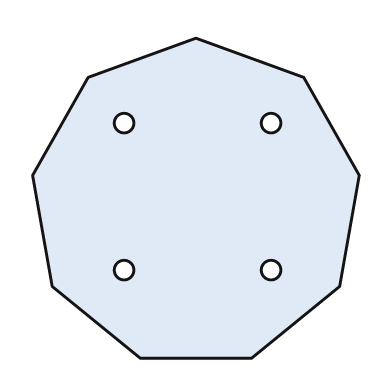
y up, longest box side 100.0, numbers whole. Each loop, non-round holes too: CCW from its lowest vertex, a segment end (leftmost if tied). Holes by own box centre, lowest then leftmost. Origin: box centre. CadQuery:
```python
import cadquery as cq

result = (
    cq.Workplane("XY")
    .moveTo(-17.0, -49.0)
    .lineTo(17.0, -49.0)
    .lineTo(44.0, -27.0)
    .lineTo(50.0, 7.0)
    .lineTo(33.0, 37.0)
    .lineTo(0.0, 49.0)
    .lineTo(-33.0, 37.0)
    .lineTo(-50.0, 7.0)
    .lineTo(-44.0, -27.0)
    .close()
    .moveTo(-22.0, -22.0)
    .circle(3.0)
    .moveTo(23.0, -22.0)
    .circle(3.0)
    .moveTo(-22.0, 23.0)
    .circle(3.0)
    .moveTo(23.0, 23.0)
    .circle(3.0)
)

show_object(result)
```